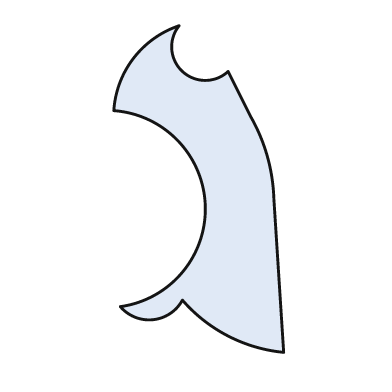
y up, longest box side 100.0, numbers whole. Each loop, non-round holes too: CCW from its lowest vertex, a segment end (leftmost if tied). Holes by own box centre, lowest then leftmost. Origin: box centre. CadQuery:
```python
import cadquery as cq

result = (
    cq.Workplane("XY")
    .moveTo(26.0, -50.0)
    .lineTo(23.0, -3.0)
    .threePointArc((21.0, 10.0), (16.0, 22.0))
    .lineTo(9.0, 36.0)
    .threePointArc((-5.0, 36.0), (-6.0, 50.0))
    .threePointArc((-20.0, 40.0), (-26.0, 24.0))
    .threePointArc((2.0, -5.0), (-24.0, -36.0))
    .threePointArc((-14.0, -40.0), (-5.0, -34.0))
    .threePointArc((9.0, -45.0), (26.0, -50.0))
    .close()
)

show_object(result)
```